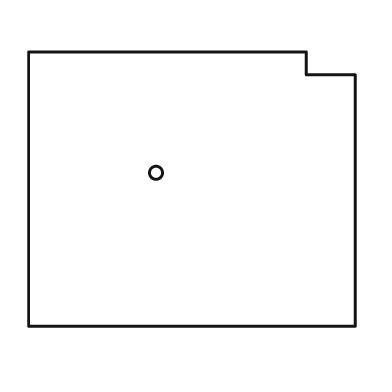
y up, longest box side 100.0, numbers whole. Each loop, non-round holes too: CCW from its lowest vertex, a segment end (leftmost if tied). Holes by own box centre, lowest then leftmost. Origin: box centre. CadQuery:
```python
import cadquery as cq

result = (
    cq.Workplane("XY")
    .moveTo(-50.0, -42.0)
    .lineTo(50.0, -42.0)
    .lineTo(50.0, 35.0)
    .lineTo(35.0, 35.0)
    .lineTo(35.0, 42.0)
    .lineTo(-50.0, 42.0)
    .close()
    .moveTo(-11.0, 5.0)
    .circle(2.0)
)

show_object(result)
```